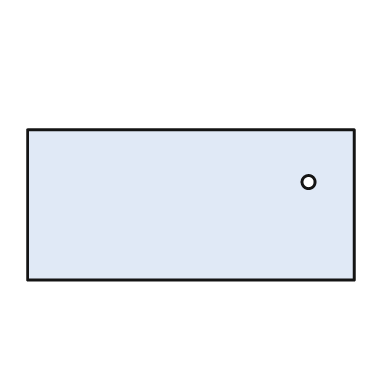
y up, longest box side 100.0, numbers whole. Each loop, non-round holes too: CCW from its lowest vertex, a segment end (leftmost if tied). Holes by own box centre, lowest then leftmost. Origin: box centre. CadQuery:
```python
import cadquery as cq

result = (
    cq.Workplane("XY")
    .moveTo(-50.0, -23.0)
    .lineTo(50.0, -23.0)
    .lineTo(50.0, 23.0)
    .lineTo(-50.0, 23.0)
    .close()
    .moveTo(36.0, 7.0)
    .circle(2.0)
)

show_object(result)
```